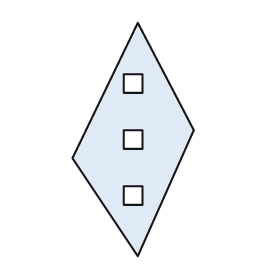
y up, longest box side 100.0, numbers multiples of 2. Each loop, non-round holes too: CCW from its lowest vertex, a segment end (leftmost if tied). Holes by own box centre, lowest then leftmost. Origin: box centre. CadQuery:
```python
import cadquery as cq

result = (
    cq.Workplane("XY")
    .moveTo(2.0, -50.0)
    .lineTo(26.0, 4.0)
    .lineTo(2.0, 50.0)
    .lineTo(-26.0, -8.0)
    .close()
    .moveTo(-4.0, -28.0)
    .lineTo(4.0, -28.0)
    .lineTo(4.0, -20.0)
    .lineTo(-4.0, -20.0)
    .close()
    .moveTo(-4.0, -4.0)
    .lineTo(4.0, -4.0)
    .lineTo(4.0, 4.0)
    .lineTo(-4.0, 4.0)
    .close()
    .moveTo(-4.0, 20.0)
    .lineTo(4.0, 20.0)
    .lineTo(4.0, 28.0)
    .lineTo(-4.0, 28.0)
    .close()
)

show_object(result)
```